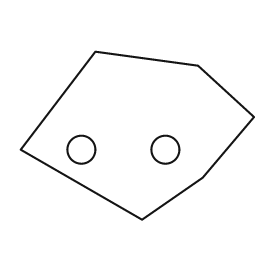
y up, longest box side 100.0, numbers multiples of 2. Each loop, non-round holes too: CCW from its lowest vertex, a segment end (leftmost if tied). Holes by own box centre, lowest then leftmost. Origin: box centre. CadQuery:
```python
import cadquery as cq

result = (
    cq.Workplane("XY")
    .moveTo(2.0, -36.0)
    .lineTo(28.0, -18.0)
    .lineTo(50.0, 8.0)
    .lineTo(26.0, 30.0)
    .lineTo(-18.0, 36.0)
    .lineTo(-50.0, -6.0)
    .close()
    .moveTo(-24.0, -6.0)
    .circle(6.0)
    .moveTo(12.0, -6.0)
    .circle(6.0)
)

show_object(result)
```